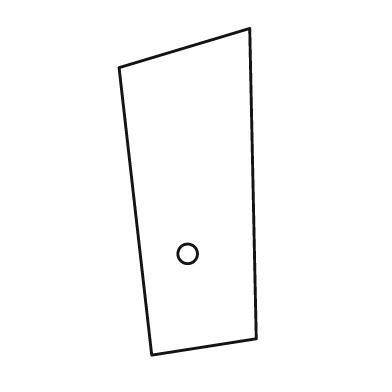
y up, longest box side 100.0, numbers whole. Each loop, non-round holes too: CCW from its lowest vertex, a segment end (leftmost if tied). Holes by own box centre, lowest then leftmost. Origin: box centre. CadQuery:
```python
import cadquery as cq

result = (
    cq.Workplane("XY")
    .moveTo(-11.0, -50.0)
    .lineTo(21.0, -45.0)
    .lineTo(19.0, 50.0)
    .lineTo(-21.0, 38.0)
    .close()
    .moveTo(0.0, -19.0)
    .circle(3.0)
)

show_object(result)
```